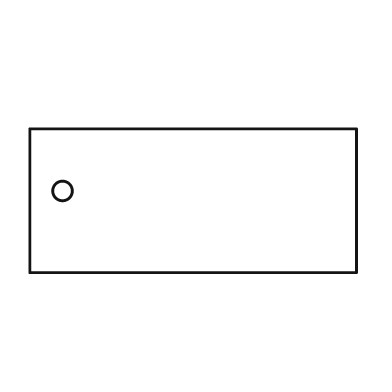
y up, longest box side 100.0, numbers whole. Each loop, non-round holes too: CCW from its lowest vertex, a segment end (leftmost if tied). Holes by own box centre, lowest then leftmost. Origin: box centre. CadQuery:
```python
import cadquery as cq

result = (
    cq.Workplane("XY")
    .moveTo(-50.0, -22.0)
    .lineTo(50.0, -22.0)
    .lineTo(50.0, 22.0)
    .lineTo(-50.0, 22.0)
    .close()
    .moveTo(-40.0, 3.0)
    .circle(3.0)
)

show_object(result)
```